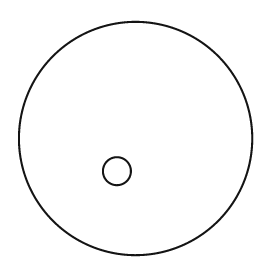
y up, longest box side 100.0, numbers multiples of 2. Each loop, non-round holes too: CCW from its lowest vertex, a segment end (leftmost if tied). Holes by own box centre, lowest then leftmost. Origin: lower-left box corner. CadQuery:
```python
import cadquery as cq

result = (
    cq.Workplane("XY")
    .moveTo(50.0, 50.0)
    .circle(50.0)
    .moveTo(42.0, 36.0)
    .circle(6.0)
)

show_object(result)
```